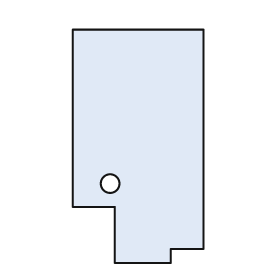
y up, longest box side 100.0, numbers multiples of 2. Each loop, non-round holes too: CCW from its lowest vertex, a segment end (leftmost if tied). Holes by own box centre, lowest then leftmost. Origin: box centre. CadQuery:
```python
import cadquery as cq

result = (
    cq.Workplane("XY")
    .moveTo(-10.0, -50.0)
    .lineTo(14.0, -50.0)
    .lineTo(14.0, -44.0)
    .lineTo(28.0, -44.0)
    .lineTo(28.0, 50.0)
    .lineTo(-28.0, 50.0)
    .lineTo(-28.0, -26.0)
    .lineTo(-10.0, -26.0)
    .close()
    .moveTo(-12.0, -16.0)
    .circle(4.0)
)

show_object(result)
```